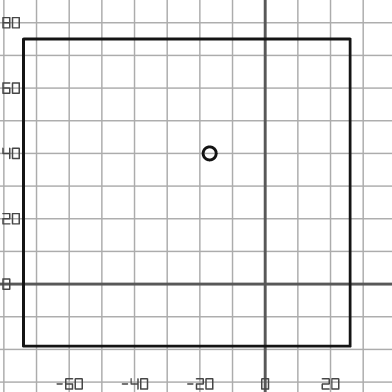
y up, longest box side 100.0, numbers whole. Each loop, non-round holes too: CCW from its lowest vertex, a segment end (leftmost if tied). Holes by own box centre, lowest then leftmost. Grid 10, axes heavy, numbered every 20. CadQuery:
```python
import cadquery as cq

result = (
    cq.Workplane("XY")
    .moveTo(-74.0, -19.0)
    .lineTo(26.0, -19.0)
    .lineTo(26.0, 75.0)
    .lineTo(-74.0, 75.0)
    .close()
    .moveTo(-17.0, 40.0)
    .circle(2.0)
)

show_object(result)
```